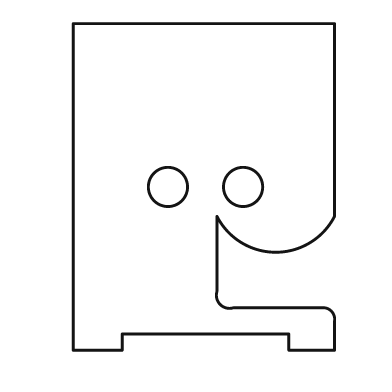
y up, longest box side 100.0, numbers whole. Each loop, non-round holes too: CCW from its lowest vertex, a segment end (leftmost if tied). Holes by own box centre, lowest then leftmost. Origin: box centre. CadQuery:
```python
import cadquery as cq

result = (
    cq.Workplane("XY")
    .moveTo(-40.0, -50.0)
    .lineTo(-25.0, -50.0)
    .lineTo(-25.0, -45.0)
    .lineTo(26.0, -45.0)
    .lineTo(26.0, -50.0)
    .lineTo(40.0, -50.0)
    .lineTo(40.0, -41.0)
    .threePointArc((39.0, -38.0), (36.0, -37.0))
    .lineTo(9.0, -37.0)
    .threePointArc((5.0, -36.0), (4.0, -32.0))
    .lineTo(4.0, -9.0)
    .threePointArc((22.0, -20.0), (40.0, -9.0))
    .lineTo(40.0, 50.0)
    .lineTo(-40.0, 50.0)
    .close()
    .moveTo(-11.0, 0.0)
    .circle(6.0)
    .moveTo(12.0, 0.0)
    .circle(6.0)
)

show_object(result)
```